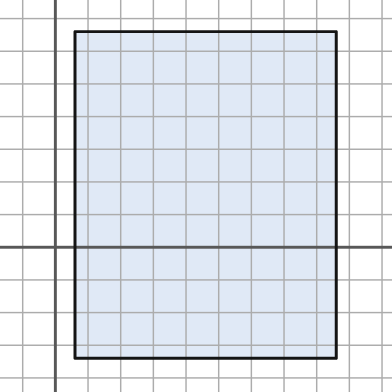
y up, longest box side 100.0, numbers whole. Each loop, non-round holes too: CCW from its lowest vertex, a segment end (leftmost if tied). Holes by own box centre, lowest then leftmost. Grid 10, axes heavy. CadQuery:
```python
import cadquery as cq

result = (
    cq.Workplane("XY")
    .moveTo(6.0, -34.0)
    .lineTo(86.0, -34.0)
    .lineTo(86.0, 66.0)
    .lineTo(6.0, 66.0)
    .close()
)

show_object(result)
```